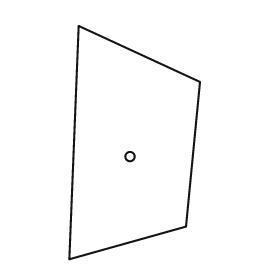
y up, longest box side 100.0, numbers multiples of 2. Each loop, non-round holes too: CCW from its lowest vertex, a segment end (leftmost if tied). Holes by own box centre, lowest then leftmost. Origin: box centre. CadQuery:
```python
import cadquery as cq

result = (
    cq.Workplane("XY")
    .moveTo(-28.0, -50.0)
    .lineTo(22.0, -36.0)
    .lineTo(28.0, 26.0)
    .lineTo(-24.0, 50.0)
    .close()
    .moveTo(-2.0, -6.0)
    .circle(2.0)
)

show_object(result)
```